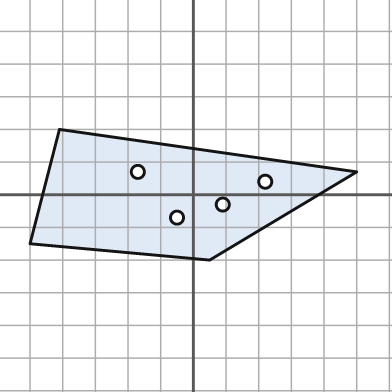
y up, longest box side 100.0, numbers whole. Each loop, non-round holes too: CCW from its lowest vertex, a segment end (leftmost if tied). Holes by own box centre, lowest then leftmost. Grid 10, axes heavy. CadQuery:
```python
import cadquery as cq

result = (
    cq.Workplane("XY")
    .moveTo(5.0, -20.0)
    .lineTo(50.0, 7.0)
    .lineTo(-41.0, 20.0)
    .lineTo(-50.0, -15.0)
    .close()
    .moveTo(-5.0, -7.0)
    .circle(2.0)
    .moveTo(9.0, -3.0)
    .circle(2.0)
    .moveTo(22.0, 4.0)
    .circle(2.0)
    .moveTo(-17.0, 7.0)
    .circle(2.0)
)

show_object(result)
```